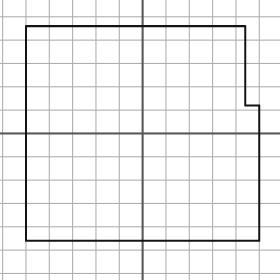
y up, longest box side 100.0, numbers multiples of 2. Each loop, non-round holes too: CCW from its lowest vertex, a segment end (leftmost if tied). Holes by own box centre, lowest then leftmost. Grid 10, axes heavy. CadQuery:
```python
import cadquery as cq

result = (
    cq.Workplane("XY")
    .moveTo(-50.0, -46.0)
    .lineTo(50.0, -46.0)
    .lineTo(50.0, 12.0)
    .lineTo(44.0, 12.0)
    .lineTo(44.0, 46.0)
    .lineTo(-50.0, 46.0)
    .close()
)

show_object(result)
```